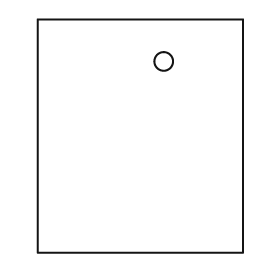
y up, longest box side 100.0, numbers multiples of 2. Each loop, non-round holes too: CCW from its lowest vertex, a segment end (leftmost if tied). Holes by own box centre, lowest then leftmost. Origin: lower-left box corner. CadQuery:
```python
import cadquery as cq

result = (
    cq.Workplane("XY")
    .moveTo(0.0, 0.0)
    .lineTo(88.0, 0.0)
    .lineTo(88.0, 100.0)
    .lineTo(0.0, 100.0)
    .close()
    .moveTo(54.0, 82.0)
    .circle(4.0)
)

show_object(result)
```